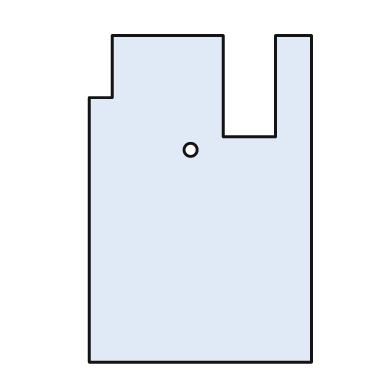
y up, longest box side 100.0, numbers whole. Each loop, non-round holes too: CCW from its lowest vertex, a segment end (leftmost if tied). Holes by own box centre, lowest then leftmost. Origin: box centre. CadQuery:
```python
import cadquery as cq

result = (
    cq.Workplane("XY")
    .moveTo(-34.0, -50.0)
    .lineTo(34.0, -50.0)
    .lineTo(34.0, 50.0)
    .lineTo(23.0, 50.0)
    .lineTo(23.0, 19.0)
    .lineTo(7.0, 19.0)
    .lineTo(7.0, 50.0)
    .lineTo(-27.0, 50.0)
    .lineTo(-27.0, 31.0)
    .lineTo(-34.0, 31.0)
    .close()
    .moveTo(-3.0, 15.0)
    .circle(2.0)
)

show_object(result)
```